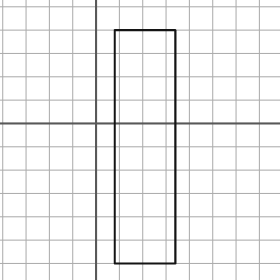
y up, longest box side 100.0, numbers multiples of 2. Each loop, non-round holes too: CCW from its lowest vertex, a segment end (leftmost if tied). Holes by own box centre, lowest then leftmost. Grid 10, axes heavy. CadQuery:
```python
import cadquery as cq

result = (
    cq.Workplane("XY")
    .moveTo(8.0, -60.0)
    .lineTo(34.0, -60.0)
    .lineTo(34.0, 40.0)
    .lineTo(8.0, 40.0)
    .close()
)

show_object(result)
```